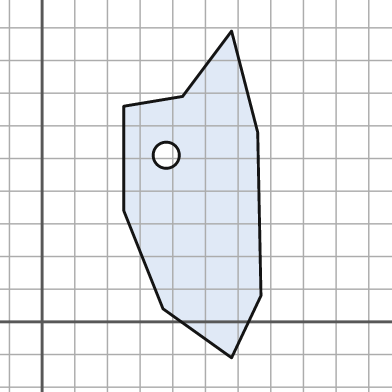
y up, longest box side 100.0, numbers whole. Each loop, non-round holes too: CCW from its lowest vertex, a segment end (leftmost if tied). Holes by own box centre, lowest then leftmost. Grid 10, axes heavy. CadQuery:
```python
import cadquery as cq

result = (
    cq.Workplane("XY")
    .moveTo(58.0, -11.0)
    .lineTo(67.0, 8.0)
    .lineTo(66.0, 58.0)
    .lineTo(58.0, 89.0)
    .lineTo(43.0, 69.0)
    .lineTo(25.0, 66.0)
    .lineTo(25.0, 34.0)
    .lineTo(37.0, 4.0)
    .close()
    .moveTo(38.0, 51.0)
    .circle(4.0)
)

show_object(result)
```